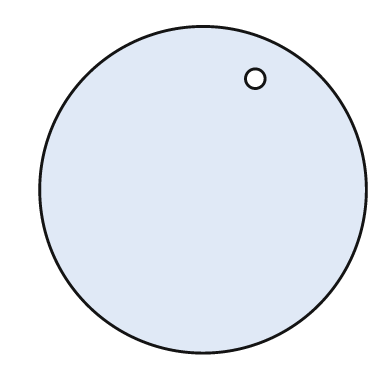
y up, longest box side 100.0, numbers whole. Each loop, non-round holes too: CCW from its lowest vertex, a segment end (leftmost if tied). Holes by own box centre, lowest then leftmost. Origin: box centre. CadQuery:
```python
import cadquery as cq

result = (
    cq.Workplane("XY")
    .moveTo(0.0, 0.0)
    .circle(50.0)
    .moveTo(16.0, 34.0)
    .circle(3.0)
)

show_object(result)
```